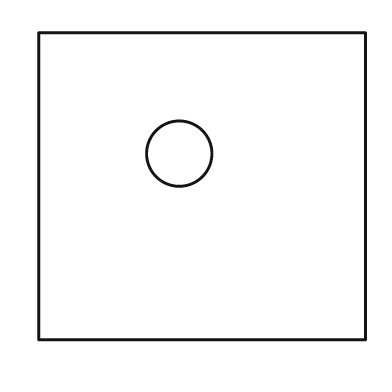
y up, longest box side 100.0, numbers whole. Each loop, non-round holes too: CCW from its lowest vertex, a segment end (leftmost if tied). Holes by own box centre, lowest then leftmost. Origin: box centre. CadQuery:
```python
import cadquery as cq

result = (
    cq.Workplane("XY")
    .moveTo(-50.0, -47.0)
    .lineTo(50.0, -47.0)
    .lineTo(50.0, 47.0)
    .lineTo(-50.0, 47.0)
    .close()
    .moveTo(-7.0, 10.0)
    .circle(10.0)
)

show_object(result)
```